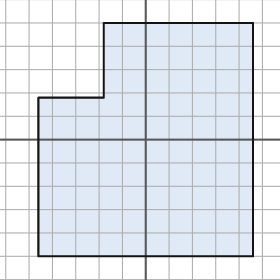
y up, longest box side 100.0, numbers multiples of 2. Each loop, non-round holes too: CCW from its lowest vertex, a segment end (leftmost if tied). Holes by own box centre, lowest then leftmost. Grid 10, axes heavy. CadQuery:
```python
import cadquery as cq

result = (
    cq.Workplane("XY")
    .moveTo(-46.0, -50.0)
    .lineTo(46.0, -50.0)
    .lineTo(46.0, 50.0)
    .lineTo(-18.0, 50.0)
    .lineTo(-18.0, 18.0)
    .lineTo(-46.0, 18.0)
    .close()
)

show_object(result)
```